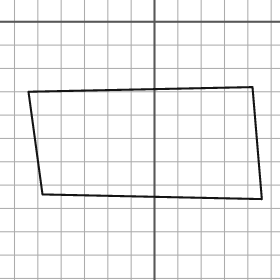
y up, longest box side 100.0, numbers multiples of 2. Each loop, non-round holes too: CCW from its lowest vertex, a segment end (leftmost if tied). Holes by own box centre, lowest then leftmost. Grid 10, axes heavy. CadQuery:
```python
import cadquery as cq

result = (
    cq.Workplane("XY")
    .moveTo(46.0, -76.0)
    .lineTo(42.0, -28.0)
    .lineTo(-54.0, -30.0)
    .lineTo(-48.0, -74.0)
    .close()
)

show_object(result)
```